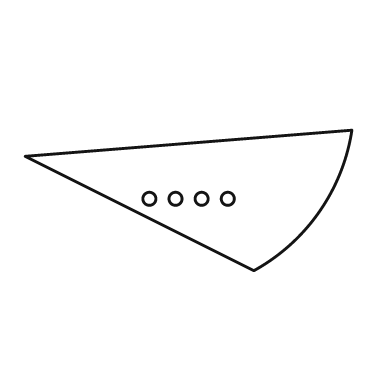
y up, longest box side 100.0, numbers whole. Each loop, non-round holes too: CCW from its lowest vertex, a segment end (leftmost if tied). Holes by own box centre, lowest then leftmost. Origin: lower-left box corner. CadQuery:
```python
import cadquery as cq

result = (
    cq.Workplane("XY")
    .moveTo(70.0, 0.0)
    .threePointArc((90.0, 18.0), (100.0, 43.0))
    .lineTo(0.0, 35.0)
    .close()
    .moveTo(38.0, 22.0)
    .circle(2.0)
    .moveTo(46.0, 22.0)
    .circle(2.0)
    .moveTo(54.0, 22.0)
    .circle(2.0)
    .moveTo(62.0, 22.0)
    .circle(2.0)
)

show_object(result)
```